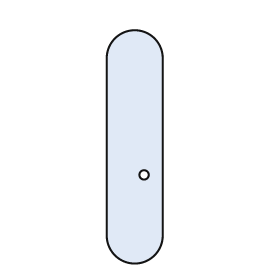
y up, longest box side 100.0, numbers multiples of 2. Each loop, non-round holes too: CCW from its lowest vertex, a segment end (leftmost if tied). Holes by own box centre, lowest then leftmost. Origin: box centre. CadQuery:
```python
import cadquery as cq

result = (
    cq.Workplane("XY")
    .moveTo(-12.0, -38.0)
    .threePointArc((0.0, -50.0), (12.0, -38.0))
    .lineTo(12.0, 38.0)
    .threePointArc((0.0, 50.0), (-12.0, 38.0))
    .close()
    .moveTo(4.0, -12.0)
    .circle(2.0)
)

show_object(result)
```